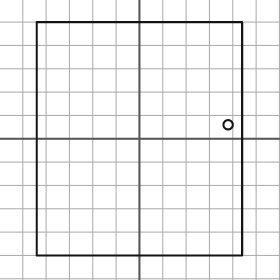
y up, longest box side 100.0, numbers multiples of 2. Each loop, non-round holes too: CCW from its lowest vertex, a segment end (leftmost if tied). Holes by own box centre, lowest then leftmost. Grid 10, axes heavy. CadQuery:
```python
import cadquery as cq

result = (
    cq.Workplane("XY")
    .moveTo(-44.0, -50.0)
    .lineTo(44.0, -50.0)
    .lineTo(44.0, 50.0)
    .lineTo(-44.0, 50.0)
    .close()
    .moveTo(38.0, 6.0)
    .circle(2.0)
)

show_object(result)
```